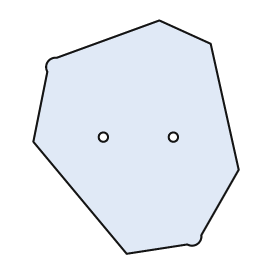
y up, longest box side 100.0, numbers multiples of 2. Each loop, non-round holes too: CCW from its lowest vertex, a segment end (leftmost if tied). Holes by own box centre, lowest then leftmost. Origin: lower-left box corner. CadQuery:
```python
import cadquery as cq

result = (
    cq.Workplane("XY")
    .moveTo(40.0, 0.0)
    .lineTo(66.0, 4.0)
    .threePointArc((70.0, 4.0), (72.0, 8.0))
    .lineTo(88.0, 36.0)
    .lineTo(76.0, 90.0)
    .lineTo(54.0, 100.0)
    .lineTo(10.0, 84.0)
    .threePointArc((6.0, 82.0), (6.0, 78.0))
    .lineTo(0.0, 48.0)
    .close()
    .moveTo(30.0, 50.0)
    .circle(2.0)
    .moveTo(60.0, 50.0)
    .circle(2.0)
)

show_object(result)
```